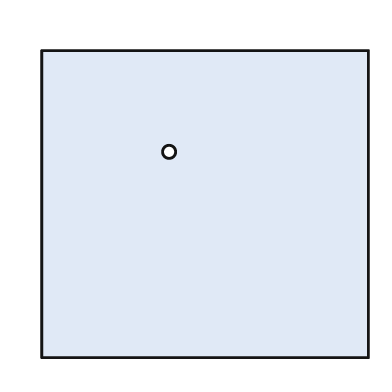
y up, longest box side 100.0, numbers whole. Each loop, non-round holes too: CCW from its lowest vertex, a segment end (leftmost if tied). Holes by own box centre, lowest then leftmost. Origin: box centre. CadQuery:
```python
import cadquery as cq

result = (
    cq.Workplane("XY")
    .moveTo(-50.0, -47.0)
    .lineTo(50.0, -47.0)
    .lineTo(50.0, 47.0)
    .lineTo(-50.0, 47.0)
    .close()
    .moveTo(-11.0, 16.0)
    .circle(2.0)
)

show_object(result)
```